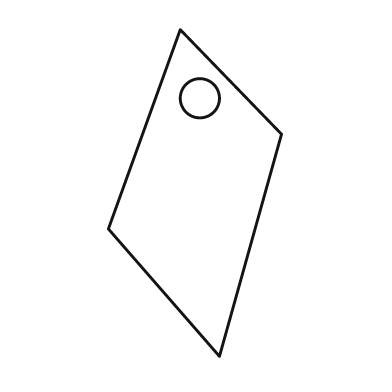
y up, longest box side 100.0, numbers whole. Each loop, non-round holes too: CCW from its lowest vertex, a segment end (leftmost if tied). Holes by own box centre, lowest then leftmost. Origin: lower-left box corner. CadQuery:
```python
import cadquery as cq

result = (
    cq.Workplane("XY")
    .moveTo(34.0, 0.0)
    .lineTo(53.0, 68.0)
    .lineTo(22.0, 100.0)
    .lineTo(0.0, 39.0)
    .close()
    .moveTo(28.0, 79.0)
    .circle(6.0)
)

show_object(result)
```